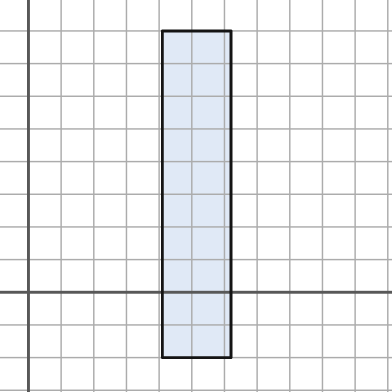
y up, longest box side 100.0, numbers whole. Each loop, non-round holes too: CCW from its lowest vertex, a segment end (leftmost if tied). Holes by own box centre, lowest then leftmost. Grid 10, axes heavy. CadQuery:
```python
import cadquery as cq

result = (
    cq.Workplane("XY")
    .moveTo(41.0, -20.0)
    .lineTo(62.0, -20.0)
    .lineTo(62.0, 80.0)
    .lineTo(41.0, 80.0)
    .close()
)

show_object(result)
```